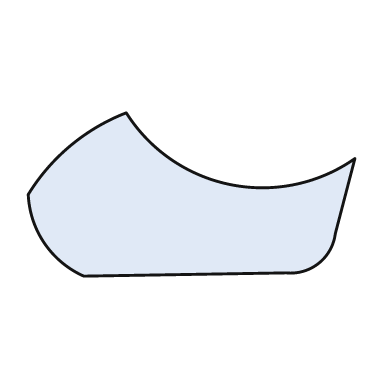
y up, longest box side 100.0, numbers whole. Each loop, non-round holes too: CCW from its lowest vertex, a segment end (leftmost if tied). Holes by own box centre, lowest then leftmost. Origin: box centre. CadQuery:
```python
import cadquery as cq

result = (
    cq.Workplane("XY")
    .moveTo(-33.0, -25.0)
    .lineTo(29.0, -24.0)
    .threePointArc((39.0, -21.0), (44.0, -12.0))
    .lineTo(50.0, 11.0)
    .threePointArc((12.0, 3.0), (-20.0, 25.0))
    .threePointArc((-37.0, 15.0), (-50.0, 0.0))
    .threePointArc((-45.0, -15.0), (-33.0, -25.0))
    .close()
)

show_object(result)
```